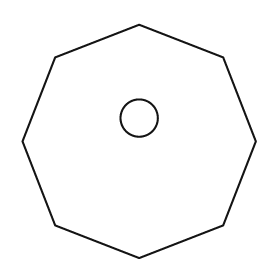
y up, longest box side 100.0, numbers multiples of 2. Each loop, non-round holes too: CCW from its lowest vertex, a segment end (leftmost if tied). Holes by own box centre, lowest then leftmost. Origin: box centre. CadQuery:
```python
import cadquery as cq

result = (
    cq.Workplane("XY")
    .moveTo(0.0, -50.0)
    .lineTo(36.0, -36.0)
    .lineTo(50.0, 0.0)
    .lineTo(36.0, 36.0)
    .lineTo(0.0, 50.0)
    .lineTo(-36.0, 36.0)
    .lineTo(-50.0, 0.0)
    .lineTo(-36.0, -36.0)
    .close()
    .moveTo(0.0, 10.0)
    .circle(8.0)
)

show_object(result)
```